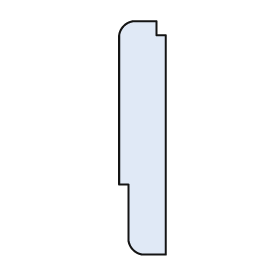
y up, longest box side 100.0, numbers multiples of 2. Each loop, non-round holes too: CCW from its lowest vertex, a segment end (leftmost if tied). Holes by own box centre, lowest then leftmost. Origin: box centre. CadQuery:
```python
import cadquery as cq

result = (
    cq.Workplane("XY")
    .moveTo(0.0, -50.0)
    .lineTo(10.0, -50.0)
    .lineTo(10.0, 44.0)
    .lineTo(6.0, 44.0)
    .lineTo(6.0, 50.0)
    .lineTo(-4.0, 50.0)
    .threePointArc((-8.0, 48.0), (-10.0, 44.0))
    .lineTo(-10.0, -20.0)
    .lineTo(-6.0, -20.0)
    .lineTo(-6.0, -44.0)
    .threePointArc((-4.0, -48.0), (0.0, -50.0))
    .close()
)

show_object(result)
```